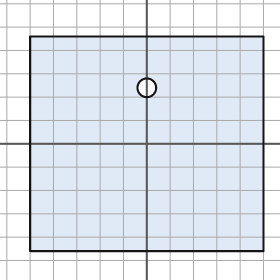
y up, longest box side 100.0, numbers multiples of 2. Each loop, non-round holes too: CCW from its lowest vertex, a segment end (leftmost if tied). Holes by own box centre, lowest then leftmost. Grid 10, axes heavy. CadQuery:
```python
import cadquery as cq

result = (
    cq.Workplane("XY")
    .moveTo(-50.0, -46.0)
    .lineTo(50.0, -46.0)
    .lineTo(50.0, 46.0)
    .lineTo(-50.0, 46.0)
    .close()
    .moveTo(0.0, 24.0)
    .circle(4.0)
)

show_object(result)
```